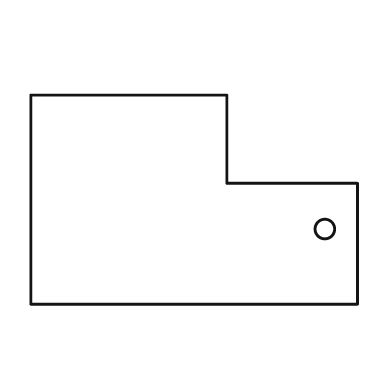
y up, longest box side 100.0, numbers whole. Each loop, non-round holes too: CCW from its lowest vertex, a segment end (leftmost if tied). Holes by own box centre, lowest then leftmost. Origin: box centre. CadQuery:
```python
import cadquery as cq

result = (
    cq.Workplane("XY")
    .moveTo(-50.0, -32.0)
    .lineTo(50.0, -32.0)
    .lineTo(50.0, 5.0)
    .lineTo(10.0, 5.0)
    .lineTo(10.0, 32.0)
    .lineTo(-50.0, 32.0)
    .close()
    .moveTo(40.0, -9.0)
    .circle(3.0)
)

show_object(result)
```